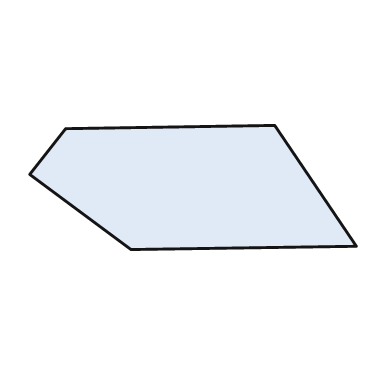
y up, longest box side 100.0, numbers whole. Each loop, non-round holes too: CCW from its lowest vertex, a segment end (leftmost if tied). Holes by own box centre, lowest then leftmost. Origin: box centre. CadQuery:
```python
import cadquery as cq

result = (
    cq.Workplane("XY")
    .moveTo(-19.0, -19.0)
    .lineTo(50.0, -18.0)
    .lineTo(25.0, 19.0)
    .lineTo(-39.0, 18.0)
    .lineTo(-50.0, 4.0)
    .close()
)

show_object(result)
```